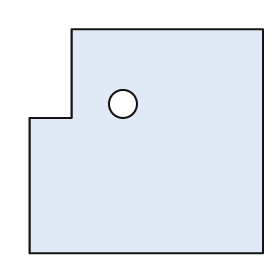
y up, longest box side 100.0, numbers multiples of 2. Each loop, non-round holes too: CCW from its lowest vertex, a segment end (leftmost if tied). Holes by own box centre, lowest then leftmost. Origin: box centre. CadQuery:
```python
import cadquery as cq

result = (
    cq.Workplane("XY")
    .moveTo(-50.0, -48.0)
    .lineTo(50.0, -48.0)
    .lineTo(50.0, 48.0)
    .lineTo(-32.0, 48.0)
    .lineTo(-32.0, 10.0)
    .lineTo(-50.0, 10.0)
    .close()
    .moveTo(-10.0, 16.0)
    .circle(6.0)
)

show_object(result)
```